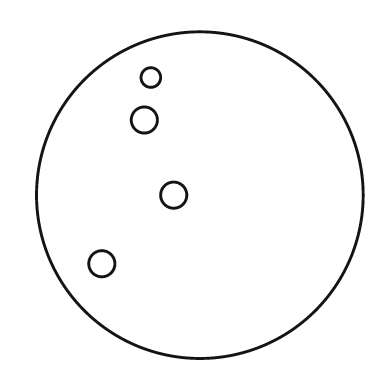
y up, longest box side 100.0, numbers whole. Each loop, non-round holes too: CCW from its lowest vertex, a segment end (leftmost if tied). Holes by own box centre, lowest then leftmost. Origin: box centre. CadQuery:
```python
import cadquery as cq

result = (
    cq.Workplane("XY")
    .moveTo(0.0, 0.0)
    .circle(50.0)
    .moveTo(-30.0, -21.0)
    .circle(4.0)
    .moveTo(-8.0, 0.0)
    .circle(4.0)
    .moveTo(-17.0, 23.0)
    .circle(4.0)
    .moveTo(-15.0, 36.0)
    .circle(3.0)
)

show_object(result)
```